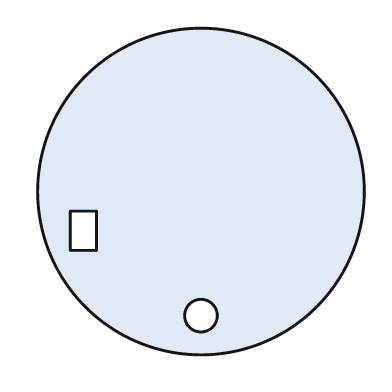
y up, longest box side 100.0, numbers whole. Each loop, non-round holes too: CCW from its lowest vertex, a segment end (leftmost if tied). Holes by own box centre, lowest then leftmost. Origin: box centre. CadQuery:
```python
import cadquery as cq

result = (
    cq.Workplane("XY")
    .moveTo(0.0, 0.0)
    .circle(50.0)
    .moveTo(0.0, -38.0)
    .circle(5.0)
    .moveTo(-40.0, -18.0)
    .lineTo(-32.0, -18.0)
    .lineTo(-32.0, -6.0)
    .lineTo(-40.0, -6.0)
    .close()
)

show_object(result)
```